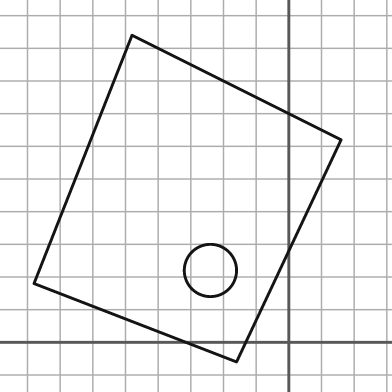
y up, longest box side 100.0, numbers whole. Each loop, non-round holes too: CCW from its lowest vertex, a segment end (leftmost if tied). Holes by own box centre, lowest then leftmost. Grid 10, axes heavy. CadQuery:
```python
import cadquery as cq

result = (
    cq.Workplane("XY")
    .moveTo(-16.0, -6.0)
    .lineTo(16.0, 62.0)
    .lineTo(-48.0, 94.0)
    .lineTo(-78.0, 18.0)
    .close()
    .moveTo(-24.0, 22.0)
    .circle(8.0)
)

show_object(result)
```